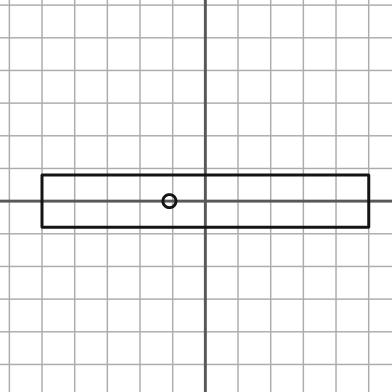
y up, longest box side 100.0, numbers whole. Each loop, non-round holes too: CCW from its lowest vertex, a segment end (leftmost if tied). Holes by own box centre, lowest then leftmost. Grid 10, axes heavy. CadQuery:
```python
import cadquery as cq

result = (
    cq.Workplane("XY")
    .moveTo(-50.0, -8.0)
    .lineTo(50.0, -8.0)
    .lineTo(50.0, 8.0)
    .lineTo(-50.0, 8.0)
    .close()
    .moveTo(-11.0, 0.0)
    .circle(2.0)
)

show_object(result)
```